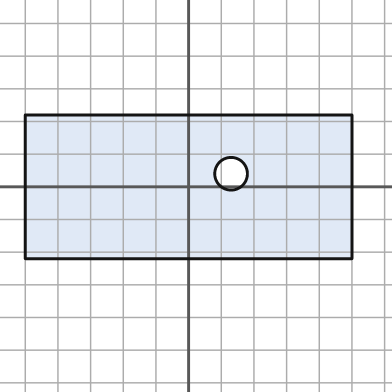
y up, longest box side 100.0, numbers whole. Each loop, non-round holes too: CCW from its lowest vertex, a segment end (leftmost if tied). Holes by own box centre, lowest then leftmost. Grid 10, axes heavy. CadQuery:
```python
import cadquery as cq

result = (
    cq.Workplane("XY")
    .moveTo(-50.0, -22.0)
    .lineTo(50.0, -22.0)
    .lineTo(50.0, 22.0)
    .lineTo(-50.0, 22.0)
    .close()
    .moveTo(13.0, 4.0)
    .circle(5.0)
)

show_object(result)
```